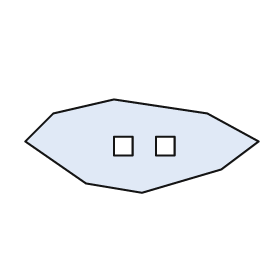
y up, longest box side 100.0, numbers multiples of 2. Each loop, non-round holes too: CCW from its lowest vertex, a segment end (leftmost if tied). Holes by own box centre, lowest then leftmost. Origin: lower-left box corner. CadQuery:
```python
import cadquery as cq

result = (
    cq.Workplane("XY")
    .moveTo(50.0, 0.0)
    .lineTo(84.0, 10.0)
    .lineTo(100.0, 22.0)
    .lineTo(78.0, 34.0)
    .lineTo(38.0, 40.0)
    .lineTo(12.0, 34.0)
    .lineTo(0.0, 22.0)
    .lineTo(26.0, 4.0)
    .close()
    .moveTo(38.0, 16.0)
    .lineTo(46.0, 16.0)
    .lineTo(46.0, 24.0)
    .lineTo(38.0, 24.0)
    .close()
    .moveTo(56.0, 16.0)
    .lineTo(64.0, 16.0)
    .lineTo(64.0, 24.0)
    .lineTo(56.0, 24.0)
    .close()
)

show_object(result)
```